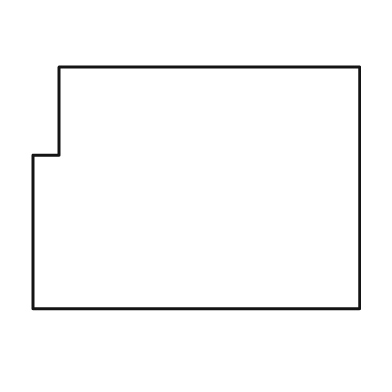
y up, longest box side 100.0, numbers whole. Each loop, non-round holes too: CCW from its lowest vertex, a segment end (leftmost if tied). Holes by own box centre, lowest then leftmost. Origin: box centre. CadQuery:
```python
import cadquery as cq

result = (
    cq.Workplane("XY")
    .moveTo(-50.0, -37.0)
    .lineTo(50.0, -37.0)
    .lineTo(50.0, 37.0)
    .lineTo(-42.0, 37.0)
    .lineTo(-42.0, 10.0)
    .lineTo(-50.0, 10.0)
    .close()
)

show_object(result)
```